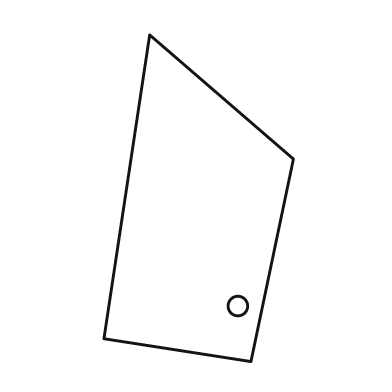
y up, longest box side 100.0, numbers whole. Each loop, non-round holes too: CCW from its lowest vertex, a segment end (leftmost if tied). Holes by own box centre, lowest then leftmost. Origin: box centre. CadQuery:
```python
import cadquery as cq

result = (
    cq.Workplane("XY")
    .moveTo(16.0, -50.0)
    .lineTo(29.0, 12.0)
    .lineTo(-15.0, 50.0)
    .lineTo(-29.0, -43.0)
    .close()
    .moveTo(12.0, -33.0)
    .circle(3.0)
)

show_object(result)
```